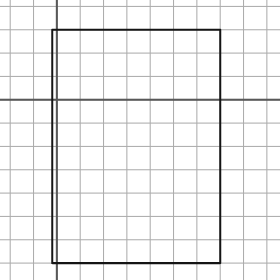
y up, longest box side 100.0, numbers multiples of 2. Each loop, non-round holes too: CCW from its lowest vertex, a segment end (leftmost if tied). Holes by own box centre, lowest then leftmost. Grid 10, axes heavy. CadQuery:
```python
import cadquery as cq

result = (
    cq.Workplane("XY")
    .moveTo(-2.0, -70.0)
    .lineTo(70.0, -70.0)
    .lineTo(70.0, 30.0)
    .lineTo(-2.0, 30.0)
    .close()
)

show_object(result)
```